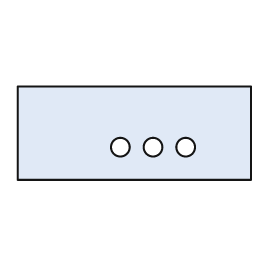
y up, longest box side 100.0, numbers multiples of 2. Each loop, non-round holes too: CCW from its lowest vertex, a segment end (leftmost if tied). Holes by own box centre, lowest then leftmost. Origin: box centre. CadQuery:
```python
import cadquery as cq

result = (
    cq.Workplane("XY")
    .moveTo(-50.0, -20.0)
    .lineTo(50.0, -20.0)
    .lineTo(50.0, 20.0)
    .lineTo(-50.0, 20.0)
    .close()
    .moveTo(-6.0, -6.0)
    .circle(4.0)
    .moveTo(8.0, -6.0)
    .circle(4.0)
    .moveTo(22.0, -6.0)
    .circle(4.0)
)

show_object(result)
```